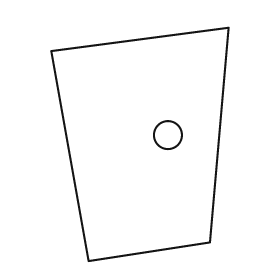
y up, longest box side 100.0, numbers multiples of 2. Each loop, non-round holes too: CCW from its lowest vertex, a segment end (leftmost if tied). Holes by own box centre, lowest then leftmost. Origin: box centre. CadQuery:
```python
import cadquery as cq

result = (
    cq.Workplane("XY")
    .moveTo(-22.0, -50.0)
    .lineTo(30.0, -42.0)
    .lineTo(38.0, 50.0)
    .lineTo(-38.0, 40.0)
    .close()
    .moveTo(12.0, 4.0)
    .circle(6.0)
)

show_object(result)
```